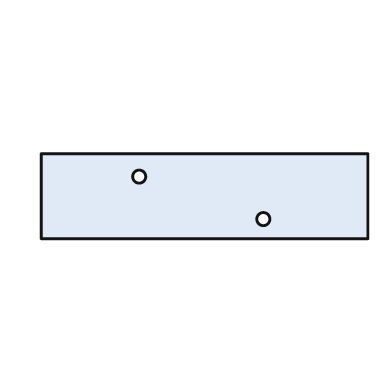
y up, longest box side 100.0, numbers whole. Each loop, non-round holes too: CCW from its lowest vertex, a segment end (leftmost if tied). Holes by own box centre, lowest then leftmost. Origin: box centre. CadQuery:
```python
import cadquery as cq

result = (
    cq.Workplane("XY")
    .moveTo(-50.0, -13.0)
    .lineTo(50.0, -13.0)
    .lineTo(50.0, 13.0)
    .lineTo(-50.0, 13.0)
    .close()
    .moveTo(18.0, -7.0)
    .circle(2.0)
    .moveTo(-20.0, 6.0)
    .circle(2.0)
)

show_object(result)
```